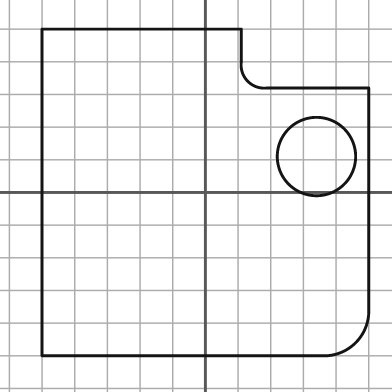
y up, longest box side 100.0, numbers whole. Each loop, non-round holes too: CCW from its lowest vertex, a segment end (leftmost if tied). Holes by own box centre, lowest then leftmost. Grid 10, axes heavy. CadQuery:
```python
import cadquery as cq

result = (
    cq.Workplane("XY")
    .moveTo(-50.0, -50.0)
    .lineTo(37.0, -50.0)
    .threePointArc((46.0, -46.0), (50.0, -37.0))
    .lineTo(50.0, 32.0)
    .lineTo(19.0, 32.0)
    .threePointArc((13.0, 34.0), (11.0, 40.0))
    .lineTo(11.0, 50.0)
    .lineTo(-50.0, 50.0)
    .close()
    .moveTo(34.0, 11.0)
    .circle(12.0)
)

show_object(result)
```